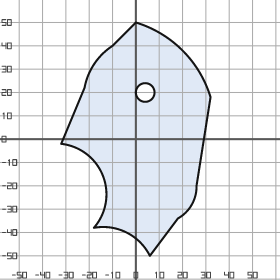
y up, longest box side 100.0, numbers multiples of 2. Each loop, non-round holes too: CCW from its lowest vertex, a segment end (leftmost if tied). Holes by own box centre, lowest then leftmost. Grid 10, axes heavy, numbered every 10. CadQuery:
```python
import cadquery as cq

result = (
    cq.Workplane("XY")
    .moveTo(6.0, -50.0)
    .lineTo(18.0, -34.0)
    .threePointArc((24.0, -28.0), (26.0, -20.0))
    .lineTo(32.0, 18.0)
    .threePointArc((20.0, 38.0), (0.0, 50.0))
    .lineTo(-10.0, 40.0)
    .threePointArc((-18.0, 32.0), (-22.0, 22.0))
    .lineTo(-32.0, -2.0)
    .threePointArc((-14.0, -16.0), (-18.0, -38.0))
    .threePointArc((-4.0, -40.0), (6.0, -50.0))
    .close()
    .moveTo(4.0, 20.0)
    .circle(4.0)
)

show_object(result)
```